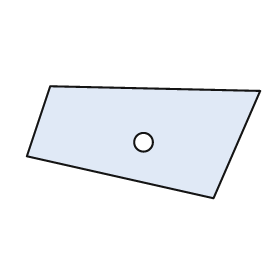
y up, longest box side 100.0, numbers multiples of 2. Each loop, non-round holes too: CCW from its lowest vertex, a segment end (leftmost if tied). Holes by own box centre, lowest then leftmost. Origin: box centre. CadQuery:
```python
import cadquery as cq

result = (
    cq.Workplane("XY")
    .moveTo(30.0, -24.0)
    .lineTo(50.0, 22.0)
    .lineTo(-40.0, 24.0)
    .lineTo(-50.0, -6.0)
    .close()
    .moveTo(0.0, 0.0)
    .circle(4.0)
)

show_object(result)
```